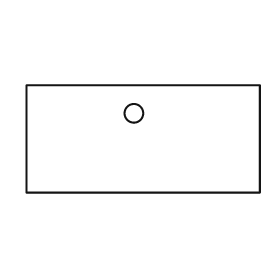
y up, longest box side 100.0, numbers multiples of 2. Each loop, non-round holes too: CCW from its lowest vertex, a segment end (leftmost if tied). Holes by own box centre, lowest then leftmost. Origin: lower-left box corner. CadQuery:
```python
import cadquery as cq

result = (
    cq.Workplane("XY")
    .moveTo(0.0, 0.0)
    .lineTo(100.0, 0.0)
    .lineTo(100.0, 46.0)
    .lineTo(0.0, 46.0)
    .close()
    .moveTo(46.0, 34.0)
    .circle(4.0)
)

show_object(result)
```